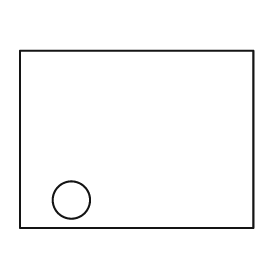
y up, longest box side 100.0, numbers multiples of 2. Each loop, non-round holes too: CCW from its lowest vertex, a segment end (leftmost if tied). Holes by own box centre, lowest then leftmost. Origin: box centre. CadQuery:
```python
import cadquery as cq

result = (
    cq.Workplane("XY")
    .moveTo(-50.0, -38.0)
    .lineTo(50.0, -38.0)
    .lineTo(50.0, 38.0)
    .lineTo(-50.0, 38.0)
    .close()
    .moveTo(-28.0, -26.0)
    .circle(8.0)
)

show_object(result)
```